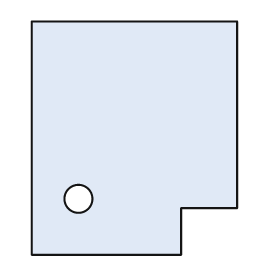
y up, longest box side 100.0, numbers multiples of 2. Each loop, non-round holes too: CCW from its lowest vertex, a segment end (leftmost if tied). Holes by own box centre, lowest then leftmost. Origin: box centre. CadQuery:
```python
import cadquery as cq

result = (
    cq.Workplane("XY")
    .moveTo(-44.0, -50.0)
    .lineTo(20.0, -50.0)
    .lineTo(20.0, -30.0)
    .lineTo(44.0, -30.0)
    .lineTo(44.0, 50.0)
    .lineTo(-44.0, 50.0)
    .close()
    .moveTo(-24.0, -26.0)
    .circle(6.0)
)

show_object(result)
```